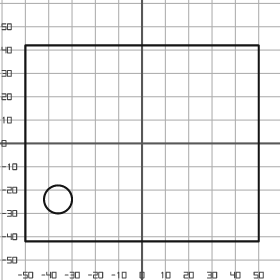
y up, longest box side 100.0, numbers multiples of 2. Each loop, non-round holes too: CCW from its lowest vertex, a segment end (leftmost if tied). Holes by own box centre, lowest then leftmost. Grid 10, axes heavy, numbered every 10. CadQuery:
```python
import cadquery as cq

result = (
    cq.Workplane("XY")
    .moveTo(-50.0, -42.0)
    .lineTo(50.0, -42.0)
    .lineTo(50.0, 42.0)
    .lineTo(-50.0, 42.0)
    .close()
    .moveTo(-36.0, -24.0)
    .circle(6.0)
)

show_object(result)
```